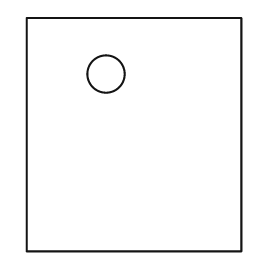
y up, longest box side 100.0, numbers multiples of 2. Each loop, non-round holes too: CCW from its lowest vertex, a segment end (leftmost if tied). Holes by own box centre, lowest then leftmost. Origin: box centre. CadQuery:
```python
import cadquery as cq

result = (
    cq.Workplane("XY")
    .moveTo(-46.0, -50.0)
    .lineTo(46.0, -50.0)
    .lineTo(46.0, 50.0)
    .lineTo(-46.0, 50.0)
    .close()
    .moveTo(-12.0, 26.0)
    .circle(8.0)
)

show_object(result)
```